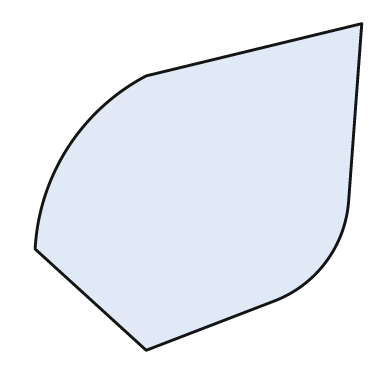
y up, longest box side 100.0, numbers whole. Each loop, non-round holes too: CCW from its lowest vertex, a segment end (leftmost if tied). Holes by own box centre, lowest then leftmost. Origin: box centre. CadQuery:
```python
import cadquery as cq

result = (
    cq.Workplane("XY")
    .moveTo(-16.0, -50.0)
    .lineTo(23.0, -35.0)
    .threePointArc((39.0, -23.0), (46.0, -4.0))
    .lineTo(50.0, 50.0)
    .lineTo(-16.0, 34.0)
    .threePointArc((-40.0, 12.0), (-50.0, -19.0))
    .close()
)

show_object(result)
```